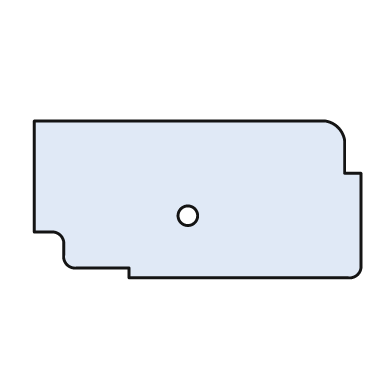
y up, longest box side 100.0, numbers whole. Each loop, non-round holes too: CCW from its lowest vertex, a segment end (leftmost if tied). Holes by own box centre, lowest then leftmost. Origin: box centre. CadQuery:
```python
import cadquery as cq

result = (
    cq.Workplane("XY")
    .moveTo(-21.0, -24.0)
    .lineTo(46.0, -24.0)
    .threePointArc((49.0, -23.0), (50.0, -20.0))
    .lineTo(50.0, 8.0)
    .lineTo(45.0, 8.0)
    .lineTo(45.0, 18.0)
    .threePointArc((43.0, 22.0), (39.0, 24.0))
    .lineTo(-50.0, 24.0)
    .lineTo(-50.0, -10.0)
    .lineTo(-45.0, -10.0)
    .threePointArc((-42.0, -11.0), (-41.0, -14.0))
    .lineTo(-41.0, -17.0)
    .threePointArc((-40.0, -20.0), (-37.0, -21.0))
    .lineTo(-21.0, -21.0)
    .close()
    .moveTo(-3.0, -5.0)
    .circle(3.0)
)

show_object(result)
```